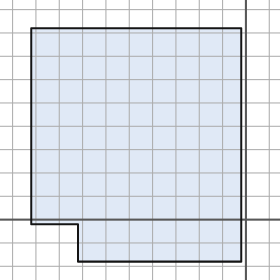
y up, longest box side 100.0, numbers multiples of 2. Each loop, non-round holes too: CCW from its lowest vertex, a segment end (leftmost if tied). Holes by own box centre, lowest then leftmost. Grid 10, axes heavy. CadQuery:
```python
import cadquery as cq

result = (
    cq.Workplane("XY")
    .moveTo(-72.0, -18.0)
    .lineTo(-2.0, -18.0)
    .lineTo(-2.0, 82.0)
    .lineTo(-92.0, 82.0)
    .lineTo(-92.0, -2.0)
    .lineTo(-72.0, -2.0)
    .close()
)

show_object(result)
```